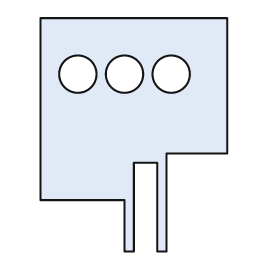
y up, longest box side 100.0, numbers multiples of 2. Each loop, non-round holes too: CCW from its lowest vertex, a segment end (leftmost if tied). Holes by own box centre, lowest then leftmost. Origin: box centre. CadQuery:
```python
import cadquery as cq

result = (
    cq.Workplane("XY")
    .moveTo(-4.0, -50.0)
    .lineTo(0.0, -50.0)
    .lineTo(0.0, -12.0)
    .lineTo(10.0, -12.0)
    .lineTo(10.0, -50.0)
    .lineTo(14.0, -50.0)
    .lineTo(14.0, -8.0)
    .lineTo(40.0, -8.0)
    .lineTo(40.0, 50.0)
    .lineTo(-40.0, 50.0)
    .lineTo(-40.0, -28.0)
    .lineTo(-4.0, -28.0)
    .close()
    .moveTo(-24.0, 26.0)
    .circle(8.0)
    .moveTo(-4.0, 26.0)
    .circle(8.0)
    .moveTo(16.0, 26.0)
    .circle(8.0)
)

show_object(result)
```